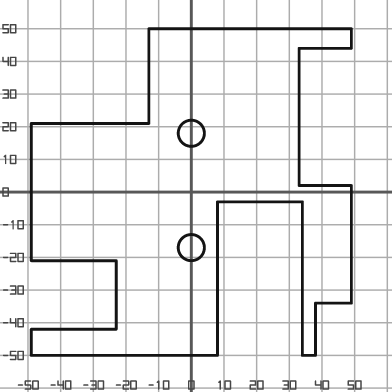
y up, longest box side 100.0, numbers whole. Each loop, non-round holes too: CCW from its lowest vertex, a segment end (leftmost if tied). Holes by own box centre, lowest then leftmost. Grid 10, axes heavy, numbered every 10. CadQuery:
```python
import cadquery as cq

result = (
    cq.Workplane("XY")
    .moveTo(-49.0, -50.0)
    .lineTo(8.0, -50.0)
    .lineTo(8.0, -3.0)
    .lineTo(34.0, -3.0)
    .lineTo(34.0, -50.0)
    .lineTo(38.0, -50.0)
    .lineTo(38.0, -34.0)
    .lineTo(49.0, -34.0)
    .lineTo(49.0, 2.0)
    .lineTo(33.0, 2.0)
    .lineTo(33.0, 44.0)
    .lineTo(49.0, 44.0)
    .lineTo(49.0, 50.0)
    .lineTo(-13.0, 50.0)
    .lineTo(-13.0, 21.0)
    .lineTo(-49.0, 21.0)
    .lineTo(-49.0, -21.0)
    .lineTo(-23.0, -21.0)
    .lineTo(-23.0, -42.0)
    .lineTo(-49.0, -42.0)
    .close()
    .moveTo(0.0, -17.0)
    .circle(4.0)
    .moveTo(0.0, 18.0)
    .circle(4.0)
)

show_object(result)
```